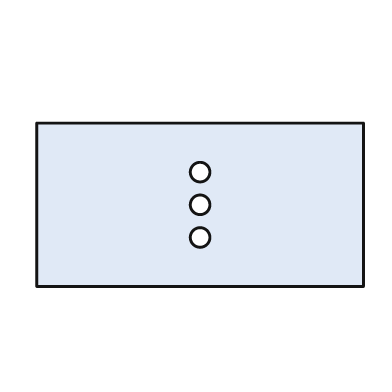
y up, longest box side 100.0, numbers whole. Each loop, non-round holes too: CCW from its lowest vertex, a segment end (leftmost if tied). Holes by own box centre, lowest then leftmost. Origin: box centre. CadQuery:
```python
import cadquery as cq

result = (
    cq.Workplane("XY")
    .moveTo(-50.0, -25.0)
    .lineTo(50.0, -25.0)
    .lineTo(50.0, 25.0)
    .lineTo(-50.0, 25.0)
    .close()
    .moveTo(0.0, -10.0)
    .circle(3.0)
    .moveTo(0.0, 0.0)
    .circle(3.0)
    .moveTo(0.0, 10.0)
    .circle(3.0)
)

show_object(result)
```